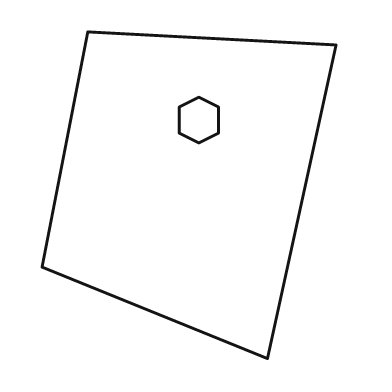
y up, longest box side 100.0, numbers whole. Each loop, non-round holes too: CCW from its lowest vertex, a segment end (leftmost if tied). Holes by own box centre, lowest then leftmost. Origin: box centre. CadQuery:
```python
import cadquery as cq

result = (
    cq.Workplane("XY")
    .moveTo(24.0, -50.0)
    .lineTo(45.0, 46.0)
    .lineTo(-31.0, 50.0)
    .lineTo(-45.0, -22.0)
    .close()
    .moveTo(3.0, 16.0)
    .lineTo(9.0, 19.0)
    .lineTo(9.0, 27.0)
    .lineTo(3.0, 30.0)
    .lineTo(-3.0, 27.0)
    .lineTo(-3.0, 19.0)
    .close()
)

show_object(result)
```